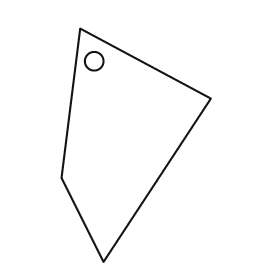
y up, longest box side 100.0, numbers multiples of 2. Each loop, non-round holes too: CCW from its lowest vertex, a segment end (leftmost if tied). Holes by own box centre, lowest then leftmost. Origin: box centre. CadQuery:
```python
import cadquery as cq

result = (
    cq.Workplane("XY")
    .moveTo(-14.0, -50.0)
    .lineTo(32.0, 20.0)
    .lineTo(-24.0, 50.0)
    .lineTo(-32.0, -14.0)
    .close()
    .moveTo(-18.0, 36.0)
    .circle(4.0)
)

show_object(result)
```